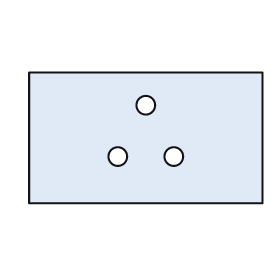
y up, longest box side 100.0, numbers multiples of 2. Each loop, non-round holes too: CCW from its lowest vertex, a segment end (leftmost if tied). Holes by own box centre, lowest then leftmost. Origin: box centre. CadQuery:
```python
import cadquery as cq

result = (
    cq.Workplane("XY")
    .moveTo(-50.0, -28.0)
    .lineTo(50.0, -28.0)
    .lineTo(50.0, 28.0)
    .lineTo(-50.0, 28.0)
    .close()
    .moveTo(-12.0, -8.0)
    .circle(4.0)
    .moveTo(12.0, -8.0)
    .circle(4.0)
    .moveTo(0.0, 14.0)
    .circle(4.0)
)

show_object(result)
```